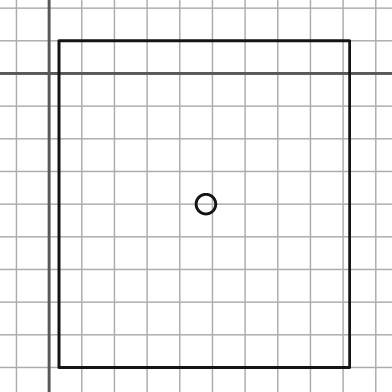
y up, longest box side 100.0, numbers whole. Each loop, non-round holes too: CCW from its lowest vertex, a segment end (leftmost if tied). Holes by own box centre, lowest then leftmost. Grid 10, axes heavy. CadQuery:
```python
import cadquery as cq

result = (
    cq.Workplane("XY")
    .moveTo(3.0, -90.0)
    .lineTo(92.0, -90.0)
    .lineTo(92.0, 10.0)
    .lineTo(3.0, 10.0)
    .close()
    .moveTo(48.0, -40.0)
    .circle(3.0)
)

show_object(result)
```